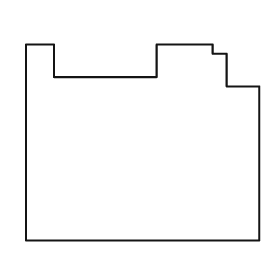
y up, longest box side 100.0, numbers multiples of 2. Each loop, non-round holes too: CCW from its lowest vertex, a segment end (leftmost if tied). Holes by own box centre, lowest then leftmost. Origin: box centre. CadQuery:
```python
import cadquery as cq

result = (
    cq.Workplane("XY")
    .moveTo(-50.0, -42.0)
    .lineTo(50.0, -42.0)
    .lineTo(50.0, 24.0)
    .lineTo(36.0, 24.0)
    .lineTo(36.0, 38.0)
    .lineTo(30.0, 38.0)
    .lineTo(30.0, 42.0)
    .lineTo(6.0, 42.0)
    .lineTo(6.0, 28.0)
    .lineTo(-38.0, 28.0)
    .lineTo(-38.0, 42.0)
    .lineTo(-50.0, 42.0)
    .close()
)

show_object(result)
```